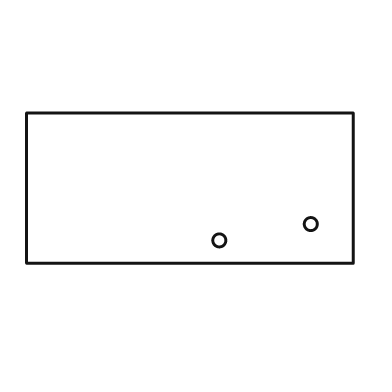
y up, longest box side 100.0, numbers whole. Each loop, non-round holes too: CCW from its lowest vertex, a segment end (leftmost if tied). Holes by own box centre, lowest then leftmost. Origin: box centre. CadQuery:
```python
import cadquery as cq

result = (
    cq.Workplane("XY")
    .moveTo(-50.0, -23.0)
    .lineTo(50.0, -23.0)
    .lineTo(50.0, 23.0)
    .lineTo(-50.0, 23.0)
    .close()
    .moveTo(9.0, -16.0)
    .circle(2.0)
    .moveTo(37.0, -11.0)
    .circle(2.0)
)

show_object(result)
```